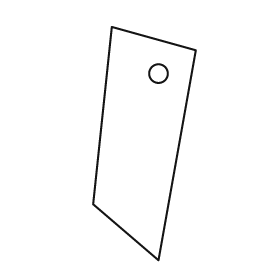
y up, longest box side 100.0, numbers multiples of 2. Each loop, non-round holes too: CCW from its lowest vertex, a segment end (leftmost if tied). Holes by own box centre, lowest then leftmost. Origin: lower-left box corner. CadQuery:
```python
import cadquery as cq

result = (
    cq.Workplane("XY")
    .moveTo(28.0, 0.0)
    .lineTo(44.0, 90.0)
    .lineTo(8.0, 100.0)
    .lineTo(0.0, 24.0)
    .close()
    .moveTo(28.0, 80.0)
    .circle(4.0)
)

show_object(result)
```